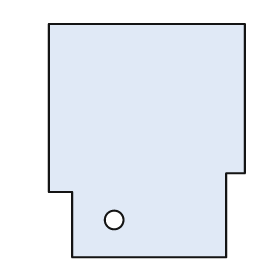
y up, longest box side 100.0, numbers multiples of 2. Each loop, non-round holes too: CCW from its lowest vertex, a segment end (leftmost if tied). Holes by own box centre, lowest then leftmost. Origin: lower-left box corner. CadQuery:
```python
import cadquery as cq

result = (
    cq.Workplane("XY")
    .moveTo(10.0, 0.0)
    .lineTo(76.0, 0.0)
    .lineTo(76.0, 36.0)
    .lineTo(84.0, 36.0)
    .lineTo(84.0, 100.0)
    .lineTo(0.0, 100.0)
    .lineTo(0.0, 28.0)
    .lineTo(10.0, 28.0)
    .close()
    .moveTo(28.0, 16.0)
    .circle(4.0)
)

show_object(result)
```